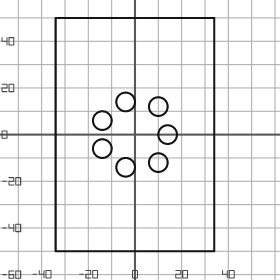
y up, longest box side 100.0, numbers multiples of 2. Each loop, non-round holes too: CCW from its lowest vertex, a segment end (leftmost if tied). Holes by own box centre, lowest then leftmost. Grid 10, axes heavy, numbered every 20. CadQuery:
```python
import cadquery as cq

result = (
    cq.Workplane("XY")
    .moveTo(-34.0, -50.0)
    .lineTo(34.0, -50.0)
    .lineTo(34.0, 50.0)
    .lineTo(-34.0, 50.0)
    .close()
    .moveTo(-4.0, -14.0)
    .circle(4.0)
    .moveTo(10.0, -12.0)
    .circle(4.0)
    .moveTo(-14.0, -6.0)
    .circle(4.0)
    .moveTo(14.0, 0.0)
    .circle(4.0)
    .moveTo(-14.0, 6.0)
    .circle(4.0)
    .moveTo(10.0, 12.0)
    .circle(4.0)
    .moveTo(-4.0, 14.0)
    .circle(4.0)
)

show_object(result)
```